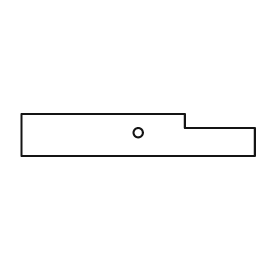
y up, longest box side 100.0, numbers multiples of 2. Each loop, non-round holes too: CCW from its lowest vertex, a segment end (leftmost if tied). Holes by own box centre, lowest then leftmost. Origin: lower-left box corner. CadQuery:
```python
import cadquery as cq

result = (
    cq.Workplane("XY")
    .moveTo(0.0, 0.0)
    .lineTo(100.0, 0.0)
    .lineTo(100.0, 12.0)
    .lineTo(70.0, 12.0)
    .lineTo(70.0, 18.0)
    .lineTo(0.0, 18.0)
    .close()
    .moveTo(50.0, 10.0)
    .circle(2.0)
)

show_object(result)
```